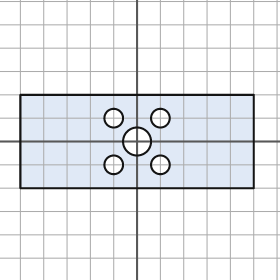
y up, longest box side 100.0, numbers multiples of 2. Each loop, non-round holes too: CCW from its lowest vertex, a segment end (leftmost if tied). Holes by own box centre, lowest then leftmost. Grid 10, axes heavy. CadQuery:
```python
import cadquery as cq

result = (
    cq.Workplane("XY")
    .moveTo(-50.0, -20.0)
    .lineTo(50.0, -20.0)
    .lineTo(50.0, 20.0)
    .lineTo(-50.0, 20.0)
    .close()
    .moveTo(-10.0, -10.0)
    .circle(4.0)
    .moveTo(10.0, -10.0)
    .circle(4.0)
    .moveTo(0.0, 0.0)
    .circle(6.0)
    .moveTo(-10.0, 10.0)
    .circle(4.0)
    .moveTo(10.0, 10.0)
    .circle(4.0)
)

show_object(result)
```